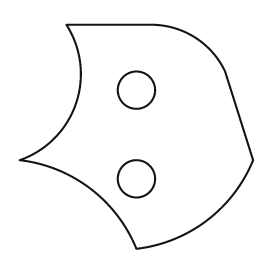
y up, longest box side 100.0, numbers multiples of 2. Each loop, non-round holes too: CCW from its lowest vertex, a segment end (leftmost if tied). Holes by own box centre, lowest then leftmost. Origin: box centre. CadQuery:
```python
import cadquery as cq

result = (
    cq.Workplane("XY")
    .moveTo(0.0, -48.0)
    .threePointArc((30.0, -36.0), (50.0, -10.0))
    .lineTo(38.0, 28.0)
    .threePointArc((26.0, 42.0), (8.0, 48.0))
    .lineTo(-30.0, 48.0)
    .threePointArc((-26.0, 14.0), (-50.0, -10.0))
    .threePointArc((-20.0, -22.0), (0.0, -48.0))
    .close()
    .moveTo(0.0, -18.0)
    .circle(8.0)
    .moveTo(0.0, 20.0)
    .circle(8.0)
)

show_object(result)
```